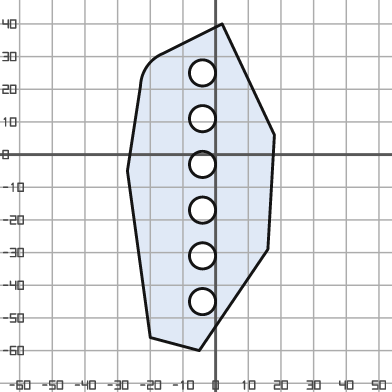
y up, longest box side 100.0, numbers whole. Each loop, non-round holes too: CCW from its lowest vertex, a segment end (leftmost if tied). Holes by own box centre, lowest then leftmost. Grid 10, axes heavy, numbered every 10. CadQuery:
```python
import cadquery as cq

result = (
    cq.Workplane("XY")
    .moveTo(-5.0, -60.0)
    .lineTo(16.0, -29.0)
    .lineTo(18.0, 6.0)
    .lineTo(2.0, 40.0)
    .lineTo(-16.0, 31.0)
    .threePointArc((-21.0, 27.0), (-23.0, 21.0))
    .lineTo(-27.0, -5.0)
    .lineTo(-20.0, -56.0)
    .close()
    .moveTo(-4.0, -45.0)
    .circle(4.0)
    .moveTo(-4.0, -31.0)
    .circle(4.0)
    .moveTo(-4.0, -17.0)
    .circle(4.0)
    .moveTo(-4.0, -3.0)
    .circle(4.0)
    .moveTo(-4.0, 11.0)
    .circle(4.0)
    .moveTo(-4.0, 25.0)
    .circle(4.0)
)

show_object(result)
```